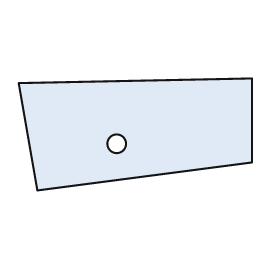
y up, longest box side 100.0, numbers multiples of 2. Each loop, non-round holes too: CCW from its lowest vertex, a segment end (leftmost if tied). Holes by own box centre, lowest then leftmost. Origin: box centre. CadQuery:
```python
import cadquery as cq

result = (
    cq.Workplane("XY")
    .moveTo(-42.0, -24.0)
    .lineTo(50.0, -12.0)
    .lineTo(50.0, 24.0)
    .lineTo(-50.0, 22.0)
    .close()
    .moveTo(-8.0, -4.0)
    .circle(4.0)
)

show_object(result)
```